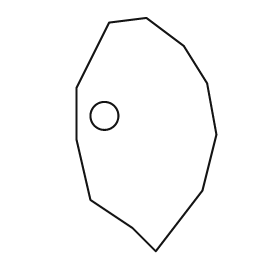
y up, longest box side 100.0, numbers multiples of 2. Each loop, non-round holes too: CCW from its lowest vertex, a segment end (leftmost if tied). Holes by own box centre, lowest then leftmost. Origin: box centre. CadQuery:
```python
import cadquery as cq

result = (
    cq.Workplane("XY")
    .moveTo(4.0, -50.0)
    .lineTo(24.0, -24.0)
    .lineTo(30.0, 0.0)
    .lineTo(26.0, 22.0)
    .lineTo(16.0, 38.0)
    .lineTo(0.0, 50.0)
    .lineTo(-16.0, 48.0)
    .lineTo(-30.0, 20.0)
    .lineTo(-30.0, -2.0)
    .lineTo(-24.0, -28.0)
    .lineTo(-6.0, -40.0)
    .close()
    .moveTo(-18.0, 8.0)
    .circle(6.0)
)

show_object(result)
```